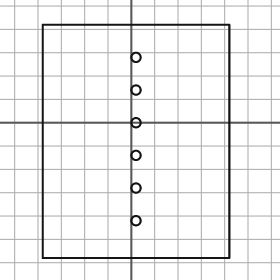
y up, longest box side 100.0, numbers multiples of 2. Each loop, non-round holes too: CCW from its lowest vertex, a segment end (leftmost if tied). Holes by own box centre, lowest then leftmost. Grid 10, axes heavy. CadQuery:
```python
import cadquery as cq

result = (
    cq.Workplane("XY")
    .moveTo(-38.0, -58.0)
    .lineTo(42.0, -58.0)
    .lineTo(42.0, 42.0)
    .lineTo(-38.0, 42.0)
    .close()
    .moveTo(2.0, -42.0)
    .circle(2.0)
    .moveTo(2.0, -28.0)
    .circle(2.0)
    .moveTo(2.0, -14.0)
    .circle(2.0)
    .moveTo(2.0, 0.0)
    .circle(2.0)
    .moveTo(2.0, 14.0)
    .circle(2.0)
    .moveTo(2.0, 28.0)
    .circle(2.0)
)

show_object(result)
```